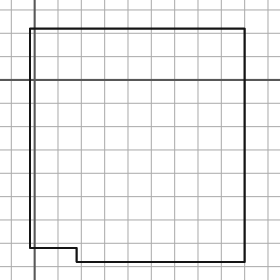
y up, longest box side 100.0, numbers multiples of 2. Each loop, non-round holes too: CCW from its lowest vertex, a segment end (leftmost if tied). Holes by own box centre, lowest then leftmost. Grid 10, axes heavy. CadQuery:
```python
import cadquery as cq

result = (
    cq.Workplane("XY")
    .moveTo(18.0, -78.0)
    .lineTo(90.0, -78.0)
    .lineTo(90.0, 22.0)
    .lineTo(-2.0, 22.0)
    .lineTo(-2.0, -72.0)
    .lineTo(18.0, -72.0)
    .close()
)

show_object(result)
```